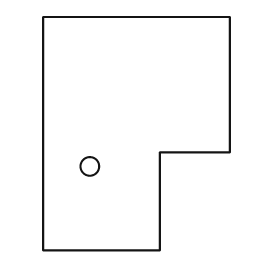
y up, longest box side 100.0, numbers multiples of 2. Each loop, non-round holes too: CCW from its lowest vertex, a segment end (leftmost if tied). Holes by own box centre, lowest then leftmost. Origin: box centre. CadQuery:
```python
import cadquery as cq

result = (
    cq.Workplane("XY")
    .moveTo(-40.0, -50.0)
    .lineTo(10.0, -50.0)
    .lineTo(10.0, -8.0)
    .lineTo(40.0, -8.0)
    .lineTo(40.0, 50.0)
    .lineTo(-40.0, 50.0)
    .close()
    .moveTo(-20.0, -14.0)
    .circle(4.0)
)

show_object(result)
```